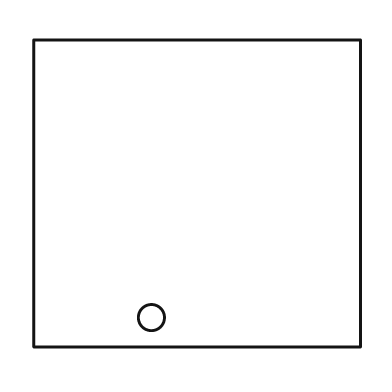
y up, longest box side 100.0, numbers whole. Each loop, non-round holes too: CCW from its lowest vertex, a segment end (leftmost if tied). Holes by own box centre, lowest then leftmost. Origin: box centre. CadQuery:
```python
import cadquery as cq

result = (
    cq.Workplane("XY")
    .moveTo(-50.0, -47.0)
    .lineTo(50.0, -47.0)
    .lineTo(50.0, 47.0)
    .lineTo(-50.0, 47.0)
    .close()
    .moveTo(-14.0, -38.0)
    .circle(4.0)
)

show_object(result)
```